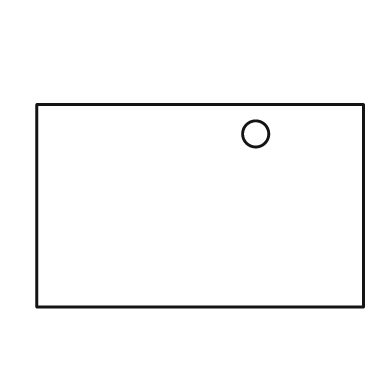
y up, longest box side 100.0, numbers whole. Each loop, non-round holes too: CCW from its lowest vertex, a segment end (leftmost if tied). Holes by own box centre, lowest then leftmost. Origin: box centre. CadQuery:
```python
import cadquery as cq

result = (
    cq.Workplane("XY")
    .moveTo(-50.0, -31.0)
    .lineTo(50.0, -31.0)
    .lineTo(50.0, 31.0)
    .lineTo(-50.0, 31.0)
    .close()
    .moveTo(17.0, 22.0)
    .circle(4.0)
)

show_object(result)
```